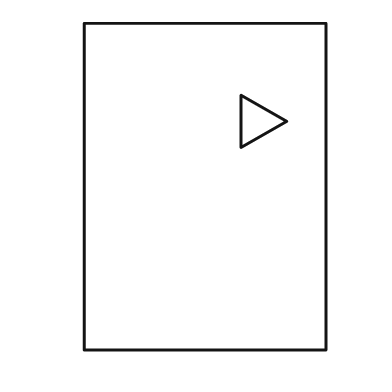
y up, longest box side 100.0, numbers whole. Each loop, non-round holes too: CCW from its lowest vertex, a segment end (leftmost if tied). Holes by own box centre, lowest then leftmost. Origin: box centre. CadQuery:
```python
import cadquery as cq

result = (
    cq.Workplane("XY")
    .moveTo(-37.0, -50.0)
    .lineTo(37.0, -50.0)
    .lineTo(37.0, 50.0)
    .lineTo(-37.0, 50.0)
    .close()
    .moveTo(11.0, 12.0)
    .lineTo(25.0, 20.0)
    .lineTo(11.0, 28.0)
    .close()
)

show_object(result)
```